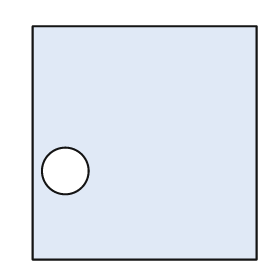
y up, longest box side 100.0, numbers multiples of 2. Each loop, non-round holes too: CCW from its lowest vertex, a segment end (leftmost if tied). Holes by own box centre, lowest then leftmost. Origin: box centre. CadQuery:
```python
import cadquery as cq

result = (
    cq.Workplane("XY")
    .moveTo(-48.0, -50.0)
    .lineTo(48.0, -50.0)
    .lineTo(48.0, 50.0)
    .lineTo(-48.0, 50.0)
    .close()
    .moveTo(-34.0, -12.0)
    .circle(10.0)
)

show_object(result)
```